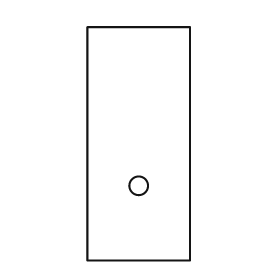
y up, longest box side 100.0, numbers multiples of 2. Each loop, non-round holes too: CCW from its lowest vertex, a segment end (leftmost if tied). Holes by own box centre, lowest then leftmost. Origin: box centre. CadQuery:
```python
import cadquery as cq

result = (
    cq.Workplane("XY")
    .moveTo(-22.0, -50.0)
    .lineTo(22.0, -50.0)
    .lineTo(22.0, 50.0)
    .lineTo(-22.0, 50.0)
    .close()
    .moveTo(0.0, -18.0)
    .circle(4.0)
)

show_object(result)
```